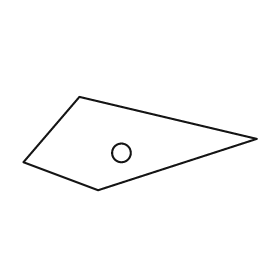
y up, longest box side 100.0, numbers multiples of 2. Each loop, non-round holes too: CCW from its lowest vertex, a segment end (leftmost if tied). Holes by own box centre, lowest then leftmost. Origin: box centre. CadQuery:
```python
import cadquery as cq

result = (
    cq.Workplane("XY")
    .moveTo(-18.0, -20.0)
    .lineTo(50.0, 2.0)
    .lineTo(-26.0, 20.0)
    .lineTo(-50.0, -8.0)
    .close()
    .moveTo(-8.0, -4.0)
    .circle(4.0)
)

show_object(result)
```